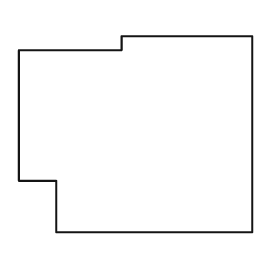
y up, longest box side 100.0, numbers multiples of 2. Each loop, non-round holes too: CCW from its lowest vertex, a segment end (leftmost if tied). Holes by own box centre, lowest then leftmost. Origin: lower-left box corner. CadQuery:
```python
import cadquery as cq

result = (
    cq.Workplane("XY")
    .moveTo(16.0, 0.0)
    .lineTo(100.0, 0.0)
    .lineTo(100.0, 84.0)
    .lineTo(44.0, 84.0)
    .lineTo(44.0, 78.0)
    .lineTo(0.0, 78.0)
    .lineTo(0.0, 22.0)
    .lineTo(16.0, 22.0)
    .close()
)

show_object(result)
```